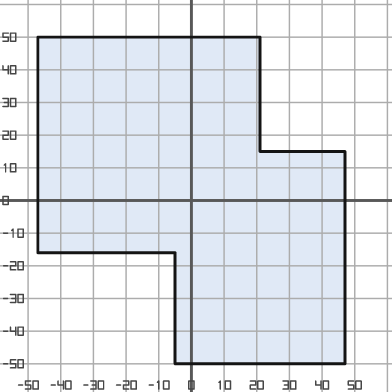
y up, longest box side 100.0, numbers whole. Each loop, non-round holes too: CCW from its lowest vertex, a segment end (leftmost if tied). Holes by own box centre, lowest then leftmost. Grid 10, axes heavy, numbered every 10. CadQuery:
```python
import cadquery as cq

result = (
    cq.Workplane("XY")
    .moveTo(-5.0, -50.0)
    .lineTo(47.0, -50.0)
    .lineTo(47.0, 15.0)
    .lineTo(21.0, 15.0)
    .lineTo(21.0, 50.0)
    .lineTo(-47.0, 50.0)
    .lineTo(-47.0, -16.0)
    .lineTo(-5.0, -16.0)
    .close()
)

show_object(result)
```